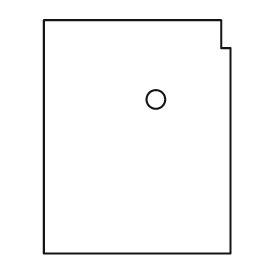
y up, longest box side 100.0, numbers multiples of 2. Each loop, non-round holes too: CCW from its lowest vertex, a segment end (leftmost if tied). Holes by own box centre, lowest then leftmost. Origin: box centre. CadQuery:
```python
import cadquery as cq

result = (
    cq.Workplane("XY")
    .moveTo(-40.0, -50.0)
    .lineTo(40.0, -50.0)
    .lineTo(40.0, 38.0)
    .lineTo(36.0, 38.0)
    .lineTo(36.0, 50.0)
    .lineTo(-40.0, 50.0)
    .close()
    .moveTo(8.0, 16.0)
    .circle(4.0)
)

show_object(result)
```